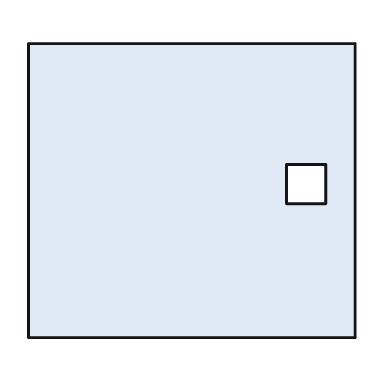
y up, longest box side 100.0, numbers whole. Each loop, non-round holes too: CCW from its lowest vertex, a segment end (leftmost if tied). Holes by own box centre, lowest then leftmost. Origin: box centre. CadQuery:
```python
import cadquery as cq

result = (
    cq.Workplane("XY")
    .moveTo(-50.0, -45.0)
    .lineTo(50.0, -45.0)
    .lineTo(50.0, 45.0)
    .lineTo(-50.0, 45.0)
    .close()
    .moveTo(29.0, -4.0)
    .lineTo(41.0, -4.0)
    .lineTo(41.0, 8.0)
    .lineTo(29.0, 8.0)
    .close()
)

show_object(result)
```